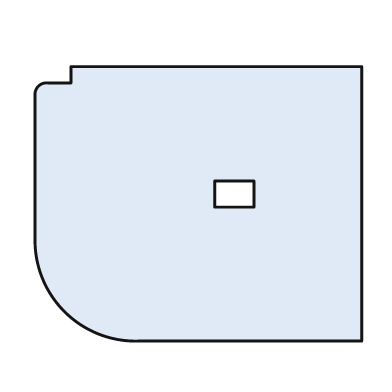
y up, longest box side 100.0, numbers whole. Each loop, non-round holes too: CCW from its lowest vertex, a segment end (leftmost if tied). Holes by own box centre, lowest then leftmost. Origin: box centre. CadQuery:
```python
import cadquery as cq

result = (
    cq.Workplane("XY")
    .moveTo(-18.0, -42.0)
    .lineTo(50.0, -42.0)
    .lineTo(50.0, 42.0)
    .lineTo(-39.0, 42.0)
    .lineTo(-39.0, 37.0)
    .lineTo(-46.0, 37.0)
    .threePointArc((-49.0, 36.0), (-50.0, 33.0))
    .lineTo(-50.0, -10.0)
    .threePointArc((-41.0, -33.0), (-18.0, -42.0))
    .close()
    .moveTo(5.0, -1.0)
    .lineTo(17.0, -1.0)
    .lineTo(17.0, 7.0)
    .lineTo(5.0, 7.0)
    .close()
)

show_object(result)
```